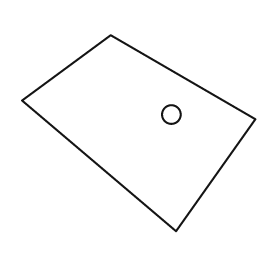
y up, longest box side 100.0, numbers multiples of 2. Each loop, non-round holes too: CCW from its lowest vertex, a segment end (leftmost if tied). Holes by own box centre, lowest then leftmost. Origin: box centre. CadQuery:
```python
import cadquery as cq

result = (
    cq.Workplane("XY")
    .moveTo(16.0, -42.0)
    .lineTo(50.0, 6.0)
    .lineTo(-12.0, 42.0)
    .lineTo(-50.0, 14.0)
    .close()
    .moveTo(14.0, 8.0)
    .circle(4.0)
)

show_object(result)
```